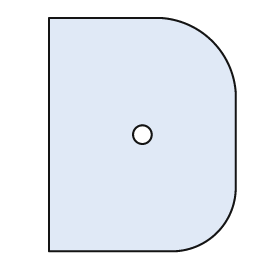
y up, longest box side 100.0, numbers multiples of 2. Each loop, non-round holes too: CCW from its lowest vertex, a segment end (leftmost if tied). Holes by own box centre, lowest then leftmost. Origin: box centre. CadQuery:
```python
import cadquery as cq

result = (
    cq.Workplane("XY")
    .moveTo(-40.0, -50.0)
    .lineTo(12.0, -50.0)
    .threePointArc((32.0, -42.0), (40.0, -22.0))
    .lineTo(40.0, 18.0)
    .threePointArc((30.0, 40.0), (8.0, 50.0))
    .lineTo(-40.0, 50.0)
    .close()
    .moveTo(0.0, 0.0)
    .circle(4.0)
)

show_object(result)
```